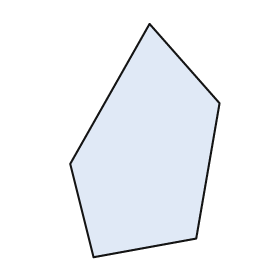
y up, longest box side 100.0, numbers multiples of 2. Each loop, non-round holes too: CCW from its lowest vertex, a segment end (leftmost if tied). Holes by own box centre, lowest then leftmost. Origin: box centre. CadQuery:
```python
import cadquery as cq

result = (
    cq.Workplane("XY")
    .moveTo(-22.0, -50.0)
    .lineTo(22.0, -42.0)
    .lineTo(32.0, 16.0)
    .lineTo(2.0, 50.0)
    .lineTo(-32.0, -10.0)
    .close()
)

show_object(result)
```